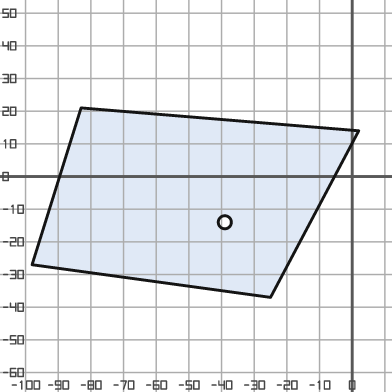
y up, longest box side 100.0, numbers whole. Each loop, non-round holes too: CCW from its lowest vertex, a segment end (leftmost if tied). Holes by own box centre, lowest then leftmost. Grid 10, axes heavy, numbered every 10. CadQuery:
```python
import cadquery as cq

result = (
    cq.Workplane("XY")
    .moveTo(-25.0, -37.0)
    .lineTo(2.0, 14.0)
    .lineTo(-83.0, 21.0)
    .lineTo(-98.0, -27.0)
    .close()
    .moveTo(-39.0, -14.0)
    .circle(2.0)
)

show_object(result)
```